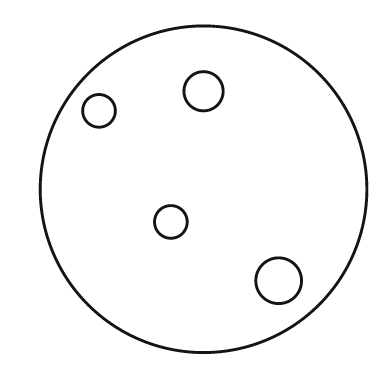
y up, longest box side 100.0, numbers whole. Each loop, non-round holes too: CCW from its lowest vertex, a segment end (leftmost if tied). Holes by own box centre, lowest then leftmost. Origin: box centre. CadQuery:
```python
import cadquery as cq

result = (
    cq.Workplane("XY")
    .moveTo(0.0, 0.0)
    .circle(50.0)
    .moveTo(23.0, -28.0)
    .circle(7.0)
    .moveTo(-10.0, -10.0)
    .circle(5.0)
    .moveTo(-32.0, 24.0)
    .circle(5.0)
    .moveTo(0.0, 30.0)
    .circle(6.0)
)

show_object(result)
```